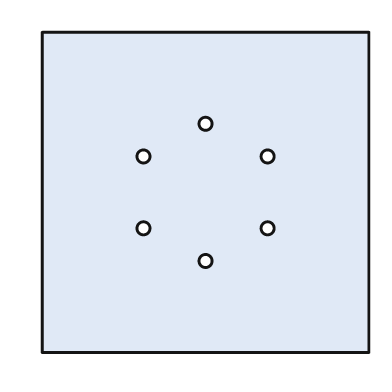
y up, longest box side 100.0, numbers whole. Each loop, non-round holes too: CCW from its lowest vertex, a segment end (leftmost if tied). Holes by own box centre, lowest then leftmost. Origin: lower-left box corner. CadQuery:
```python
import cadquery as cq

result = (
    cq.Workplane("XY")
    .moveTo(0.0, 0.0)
    .lineTo(100.0, 0.0)
    .lineTo(100.0, 98.0)
    .lineTo(0.0, 98.0)
    .close()
    .moveTo(50.0, 28.0)
    .circle(2.0)
    .moveTo(31.0, 38.0)
    .circle(2.0)
    .moveTo(69.0, 38.0)
    .circle(2.0)
    .moveTo(31.0, 60.0)
    .circle(2.0)
    .moveTo(69.0, 60.0)
    .circle(2.0)
    .moveTo(50.0, 70.0)
    .circle(2.0)
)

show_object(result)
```